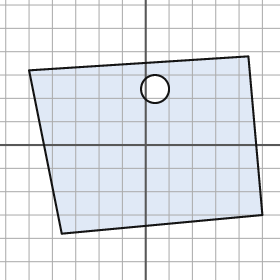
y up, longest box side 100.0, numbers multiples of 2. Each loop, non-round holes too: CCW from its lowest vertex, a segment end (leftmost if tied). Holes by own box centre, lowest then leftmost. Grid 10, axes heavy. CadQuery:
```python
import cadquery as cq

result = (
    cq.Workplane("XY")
    .moveTo(-36.0, -38.0)
    .lineTo(50.0, -30.0)
    .lineTo(44.0, 38.0)
    .lineTo(-50.0, 32.0)
    .close()
    .moveTo(4.0, 24.0)
    .circle(6.0)
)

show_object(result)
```